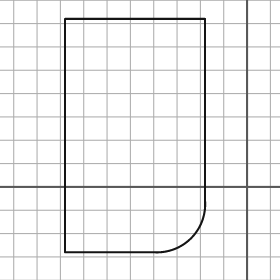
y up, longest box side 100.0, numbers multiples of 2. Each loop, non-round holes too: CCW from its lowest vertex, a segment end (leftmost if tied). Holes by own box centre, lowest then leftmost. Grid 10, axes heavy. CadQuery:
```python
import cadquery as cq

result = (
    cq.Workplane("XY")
    .moveTo(-78.0, -28.0)
    .lineTo(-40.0, -28.0)
    .threePointArc((-24.0, -22.0), (-18.0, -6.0))
    .lineTo(-18.0, 72.0)
    .lineTo(-78.0, 72.0)
    .close()
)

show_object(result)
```